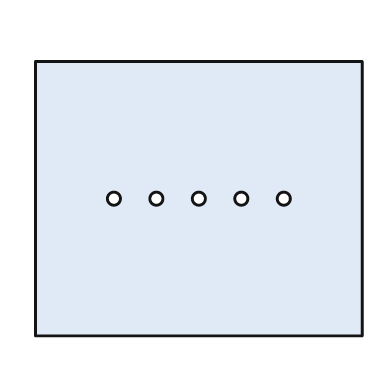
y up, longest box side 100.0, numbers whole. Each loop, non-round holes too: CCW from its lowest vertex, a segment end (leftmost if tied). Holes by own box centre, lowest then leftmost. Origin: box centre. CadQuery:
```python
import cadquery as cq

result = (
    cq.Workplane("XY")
    .moveTo(-50.0, -42.0)
    .lineTo(50.0, -42.0)
    .lineTo(50.0, 42.0)
    .lineTo(-50.0, 42.0)
    .close()
    .moveTo(-26.0, 0.0)
    .circle(2.0)
    .moveTo(-13.0, 0.0)
    .circle(2.0)
    .moveTo(0.0, 0.0)
    .circle(2.0)
    .moveTo(13.0, 0.0)
    .circle(2.0)
    .moveTo(26.0, 0.0)
    .circle(2.0)
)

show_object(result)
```